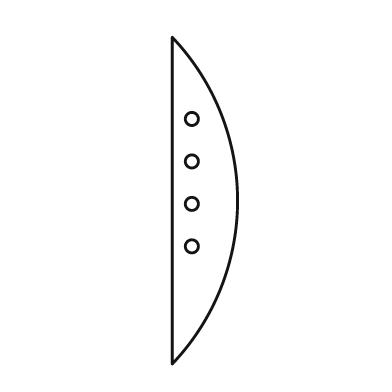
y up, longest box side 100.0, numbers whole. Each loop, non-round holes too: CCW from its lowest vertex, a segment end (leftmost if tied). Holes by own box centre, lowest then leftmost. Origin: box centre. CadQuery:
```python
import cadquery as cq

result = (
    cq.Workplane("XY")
    .moveTo(-10.0, -50.0)
    .threePointArc((10.0, 0.0), (-10.0, 50.0))
    .close()
    .moveTo(-4.0, -14.0)
    .circle(2.0)
    .moveTo(-4.0, -1.0)
    .circle(2.0)
    .moveTo(-4.0, 12.0)
    .circle(2.0)
    .moveTo(-4.0, 25.0)
    .circle(2.0)
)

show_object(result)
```